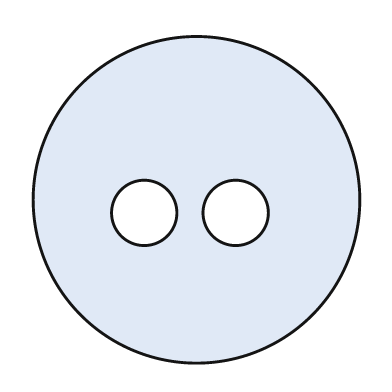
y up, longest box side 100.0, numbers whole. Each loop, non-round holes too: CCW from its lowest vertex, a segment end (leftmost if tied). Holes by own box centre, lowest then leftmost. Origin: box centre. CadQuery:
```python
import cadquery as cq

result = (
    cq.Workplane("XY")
    .moveTo(0.0, 0.0)
    .circle(50.0)
    .moveTo(-16.0, -4.0)
    .circle(10.0)
    .moveTo(12.0, -4.0)
    .circle(10.0)
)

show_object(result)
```